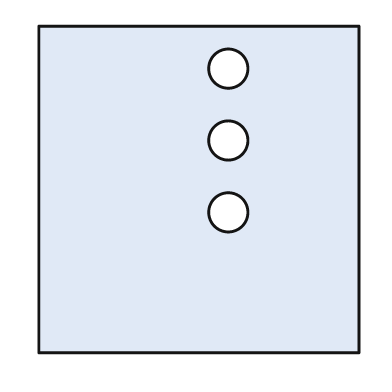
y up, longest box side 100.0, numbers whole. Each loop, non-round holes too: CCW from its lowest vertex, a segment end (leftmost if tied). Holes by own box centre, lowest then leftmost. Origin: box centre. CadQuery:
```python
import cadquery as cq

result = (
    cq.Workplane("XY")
    .moveTo(-49.0, -50.0)
    .lineTo(49.0, -50.0)
    .lineTo(49.0, 50.0)
    .lineTo(-49.0, 50.0)
    .close()
    .moveTo(9.0, -7.0)
    .circle(6.0)
    .moveTo(9.0, 15.0)
    .circle(6.0)
    .moveTo(9.0, 37.0)
    .circle(6.0)
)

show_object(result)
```